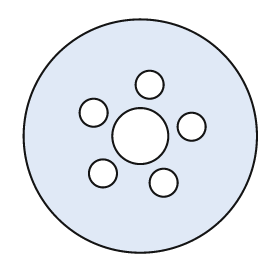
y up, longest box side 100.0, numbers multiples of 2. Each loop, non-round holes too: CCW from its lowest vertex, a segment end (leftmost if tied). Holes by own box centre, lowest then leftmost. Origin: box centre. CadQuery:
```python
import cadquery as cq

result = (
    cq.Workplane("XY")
    .moveTo(0.0, 0.0)
    .circle(50.0)
    .moveTo(10.0, -20.0)
    .circle(6.0)
    .moveTo(-16.0, -16.0)
    .circle(6.0)
    .moveTo(0.0, 0.0)
    .circle(12.0)
    .moveTo(22.0, 4.0)
    .circle(6.0)
    .moveTo(-20.0, 10.0)
    .circle(6.0)
    .moveTo(4.0, 22.0)
    .circle(6.0)
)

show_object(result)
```